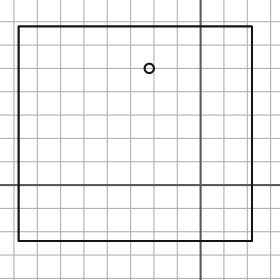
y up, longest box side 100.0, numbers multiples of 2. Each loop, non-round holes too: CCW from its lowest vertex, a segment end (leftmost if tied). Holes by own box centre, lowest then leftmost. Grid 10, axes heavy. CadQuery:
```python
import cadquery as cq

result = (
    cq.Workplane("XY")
    .moveTo(-78.0, -24.0)
    .lineTo(22.0, -24.0)
    .lineTo(22.0, 68.0)
    .lineTo(-78.0, 68.0)
    .close()
    .moveTo(-22.0, 50.0)
    .circle(2.0)
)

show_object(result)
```